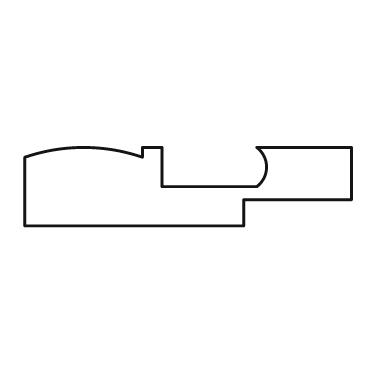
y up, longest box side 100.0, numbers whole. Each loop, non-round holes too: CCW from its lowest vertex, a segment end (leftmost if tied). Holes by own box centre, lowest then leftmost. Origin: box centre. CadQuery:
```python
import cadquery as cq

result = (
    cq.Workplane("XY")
    .moveTo(-50.0, -12.0)
    .lineTo(17.0, -12.0)
    .lineTo(17.0, -4.0)
    .lineTo(50.0, -4.0)
    .lineTo(50.0, 12.0)
    .lineTo(21.0, 12.0)
    .threePointArc((24.0, 6.0), (21.0, 0.0))
    .lineTo(-8.0, 0.0)
    .lineTo(-8.0, 12.0)
    .lineTo(-14.0, 12.0)
    .lineTo(-14.0, 9.0)
    .threePointArc((-32.0, 12.0), (-50.0, 9.0))
    .close()
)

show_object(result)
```